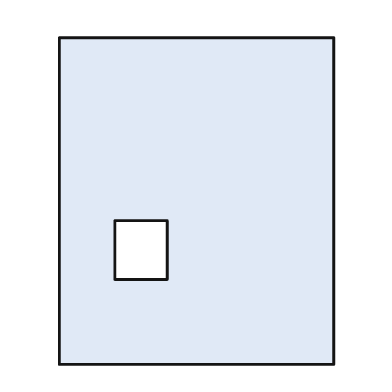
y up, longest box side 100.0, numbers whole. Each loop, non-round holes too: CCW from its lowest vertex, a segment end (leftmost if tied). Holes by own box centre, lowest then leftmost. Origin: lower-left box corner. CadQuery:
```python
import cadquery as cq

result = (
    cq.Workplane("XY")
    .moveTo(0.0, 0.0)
    .lineTo(84.0, 0.0)
    .lineTo(84.0, 100.0)
    .lineTo(0.0, 100.0)
    .close()
    .moveTo(17.0, 26.0)
    .lineTo(33.0, 26.0)
    .lineTo(33.0, 44.0)
    .lineTo(17.0, 44.0)
    .close()
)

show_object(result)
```